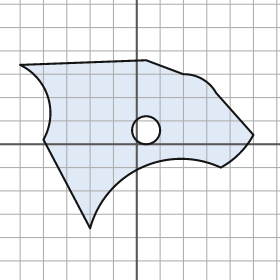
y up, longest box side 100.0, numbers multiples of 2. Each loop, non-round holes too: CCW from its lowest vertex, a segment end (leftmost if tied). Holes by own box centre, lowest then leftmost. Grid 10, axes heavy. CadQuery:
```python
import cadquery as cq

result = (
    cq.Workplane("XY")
    .moveTo(-20.0, -36.0)
    .threePointArc((2.0, -10.0), (36.0, -10.0))
    .threePointArc((44.0, -4.0), (50.0, 4.0))
    .lineTo(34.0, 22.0)
    .threePointArc((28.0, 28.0), (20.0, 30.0))
    .lineTo(4.0, 36.0)
    .lineTo(-50.0, 34.0)
    .threePointArc((-38.0, 20.0), (-40.0, 2.0))
    .close()
    .moveTo(4.0, 6.0)
    .circle(6.0)
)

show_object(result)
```